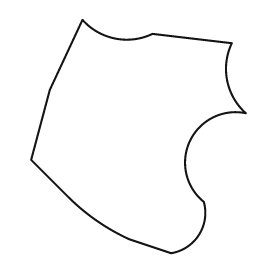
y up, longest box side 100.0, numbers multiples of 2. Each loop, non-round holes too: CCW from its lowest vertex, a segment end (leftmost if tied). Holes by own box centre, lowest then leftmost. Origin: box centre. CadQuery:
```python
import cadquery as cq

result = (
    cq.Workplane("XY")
    .moveTo(14.0, -50.0)
    .threePointArc((26.0, -42.0), (28.0, -28.0))
    .threePointArc((22.0, -2.0), (46.0, 10.0))
    .threePointArc((38.0, 24.0), (40.0, 40.0))
    .lineTo(6.0, 44.0)
    .threePointArc((-10.0, 42.0), (-24.0, 50.0))
    .lineTo(-38.0, 20.0)
    .lineTo(-46.0, -10.0)
    .lineTo(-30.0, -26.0)
    .threePointArc((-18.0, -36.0), (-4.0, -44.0))
    .close()
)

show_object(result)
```